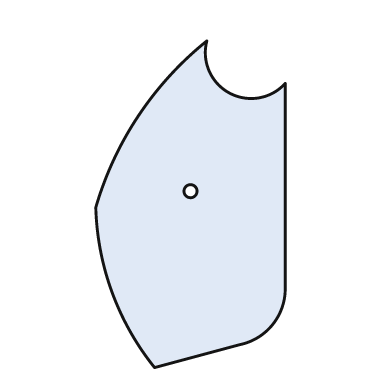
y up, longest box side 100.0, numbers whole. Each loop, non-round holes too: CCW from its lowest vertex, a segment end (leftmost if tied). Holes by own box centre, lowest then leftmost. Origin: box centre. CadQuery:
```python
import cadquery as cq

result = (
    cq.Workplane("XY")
    .moveTo(-11.0, -50.0)
    .lineTo(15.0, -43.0)
    .threePointArc((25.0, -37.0), (29.0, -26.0))
    .lineTo(29.0, 37.0)
    .threePointArc((12.0, 34.0), (5.0, 50.0))
    .threePointArc((-16.0, 27.0), (-29.0, -1.0))
    .threePointArc((-24.0, -27.0), (-11.0, -50.0))
    .close()
    .moveTo(0.0, 4.0)
    .circle(2.0)
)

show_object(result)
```